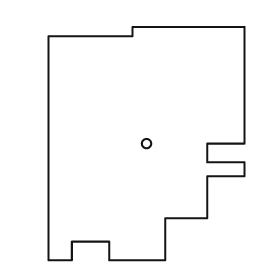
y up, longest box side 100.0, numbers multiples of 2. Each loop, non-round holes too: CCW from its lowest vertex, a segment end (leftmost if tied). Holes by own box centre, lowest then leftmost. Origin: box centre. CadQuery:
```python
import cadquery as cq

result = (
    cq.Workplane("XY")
    .moveTo(-42.0, -50.0)
    .lineTo(-32.0, -50.0)
    .lineTo(-32.0, -42.0)
    .lineTo(-16.0, -42.0)
    .lineTo(-16.0, -50.0)
    .lineTo(8.0, -50.0)
    .lineTo(8.0, -32.0)
    .lineTo(26.0, -32.0)
    .lineTo(26.0, -14.0)
    .lineTo(42.0, -14.0)
    .lineTo(42.0, -8.0)
    .lineTo(26.0, -8.0)
    .lineTo(26.0, 0.0)
    .lineTo(42.0, 0.0)
    .lineTo(42.0, 50.0)
    .lineTo(-6.0, 50.0)
    .lineTo(-6.0, 46.0)
    .lineTo(-42.0, 46.0)
    .close()
    .moveTo(0.0, 0.0)
    .circle(2.0)
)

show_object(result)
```